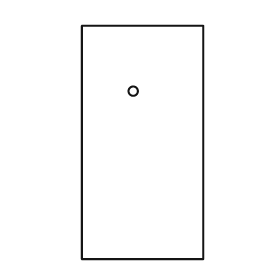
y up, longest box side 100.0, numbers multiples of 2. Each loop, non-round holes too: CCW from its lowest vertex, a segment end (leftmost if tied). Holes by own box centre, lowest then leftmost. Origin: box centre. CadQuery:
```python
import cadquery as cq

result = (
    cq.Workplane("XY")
    .moveTo(-26.0, -50.0)
    .lineTo(26.0, -50.0)
    .lineTo(26.0, 50.0)
    .lineTo(-26.0, 50.0)
    .close()
    .moveTo(-4.0, 22.0)
    .circle(2.0)
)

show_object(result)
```